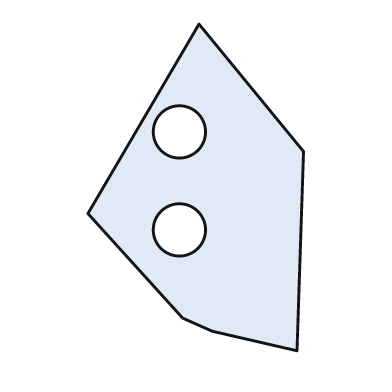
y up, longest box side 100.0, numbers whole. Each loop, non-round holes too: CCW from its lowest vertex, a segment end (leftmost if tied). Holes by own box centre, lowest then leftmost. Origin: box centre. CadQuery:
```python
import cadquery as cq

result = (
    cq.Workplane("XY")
    .moveTo(31.0, -50.0)
    .lineTo(33.0, 11.0)
    .lineTo(1.0, 50.0)
    .lineTo(-33.0, -8.0)
    .lineTo(-4.0, -40.0)
    .lineTo(5.0, -44.0)
    .close()
    .moveTo(-5.0, -13.0)
    .circle(8.0)
    .moveTo(-5.0, 17.0)
    .circle(8.0)
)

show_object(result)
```